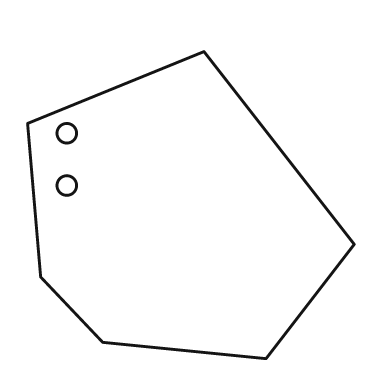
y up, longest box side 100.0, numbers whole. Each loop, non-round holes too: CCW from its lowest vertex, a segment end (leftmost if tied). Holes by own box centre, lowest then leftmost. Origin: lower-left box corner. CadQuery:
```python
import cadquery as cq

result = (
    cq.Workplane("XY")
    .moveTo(73.0, 0.0)
    .lineTo(100.0, 35.0)
    .lineTo(54.0, 94.0)
    .lineTo(0.0, 72.0)
    .lineTo(4.0, 25.0)
    .lineTo(23.0, 5.0)
    .close()
    .moveTo(12.0, 53.0)
    .circle(3.0)
    .moveTo(12.0, 69.0)
    .circle(3.0)
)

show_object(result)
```